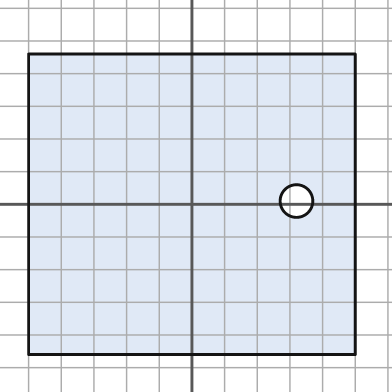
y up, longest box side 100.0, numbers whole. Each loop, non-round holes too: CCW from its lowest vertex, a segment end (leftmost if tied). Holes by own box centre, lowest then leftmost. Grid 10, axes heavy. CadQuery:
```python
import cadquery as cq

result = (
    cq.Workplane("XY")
    .moveTo(-50.0, -46.0)
    .lineTo(50.0, -46.0)
    .lineTo(50.0, 46.0)
    .lineTo(-50.0, 46.0)
    .close()
    .moveTo(32.0, 1.0)
    .circle(5.0)
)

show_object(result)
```